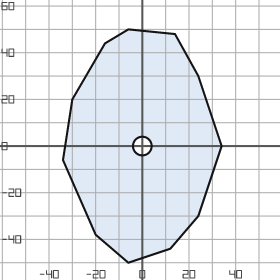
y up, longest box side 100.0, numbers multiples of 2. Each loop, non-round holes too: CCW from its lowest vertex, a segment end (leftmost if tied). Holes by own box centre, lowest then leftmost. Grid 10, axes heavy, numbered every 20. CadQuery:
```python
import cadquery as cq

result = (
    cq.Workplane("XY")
    .moveTo(-6.0, -50.0)
    .lineTo(12.0, -44.0)
    .lineTo(24.0, -30.0)
    .lineTo(34.0, 0.0)
    .lineTo(24.0, 30.0)
    .lineTo(14.0, 48.0)
    .lineTo(-6.0, 50.0)
    .lineTo(-16.0, 44.0)
    .lineTo(-30.0, 20.0)
    .lineTo(-34.0, -6.0)
    .lineTo(-20.0, -38.0)
    .close()
    .moveTo(0.0, 0.0)
    .circle(4.0)
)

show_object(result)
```